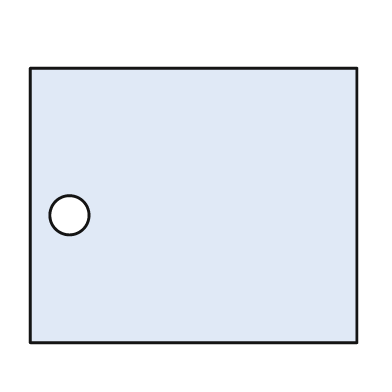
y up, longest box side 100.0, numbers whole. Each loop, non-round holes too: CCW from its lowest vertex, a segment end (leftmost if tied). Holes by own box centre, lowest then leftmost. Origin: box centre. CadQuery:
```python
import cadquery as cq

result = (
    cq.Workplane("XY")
    .moveTo(-50.0, -42.0)
    .lineTo(50.0, -42.0)
    .lineTo(50.0, 42.0)
    .lineTo(-50.0, 42.0)
    .close()
    .moveTo(-38.0, -3.0)
    .circle(6.0)
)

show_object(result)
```